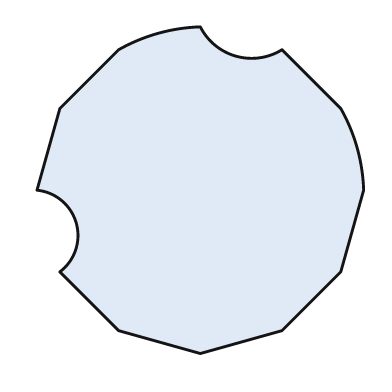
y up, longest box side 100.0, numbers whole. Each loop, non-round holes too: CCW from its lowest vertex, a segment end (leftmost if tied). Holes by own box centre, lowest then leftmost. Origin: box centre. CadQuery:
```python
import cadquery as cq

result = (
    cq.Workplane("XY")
    .moveTo(0.0, -50.0)
    .lineTo(25.0, -43.0)
    .lineTo(43.0, -25.0)
    .lineTo(50.0, 0.0)
    .threePointArc((48.0, 13.0), (43.0, 25.0))
    .lineTo(25.0, 43.0)
    .threePointArc((11.0, 41.0), (0.0, 50.0))
    .threePointArc((-13.0, 48.0), (-25.0, 43.0))
    .lineTo(-43.0, 25.0)
    .lineTo(-50.0, 0.0)
    .threePointArc((-38.0, -10.0), (-43.0, -25.0))
    .lineTo(-25.0, -43.0)
    .close()
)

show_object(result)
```